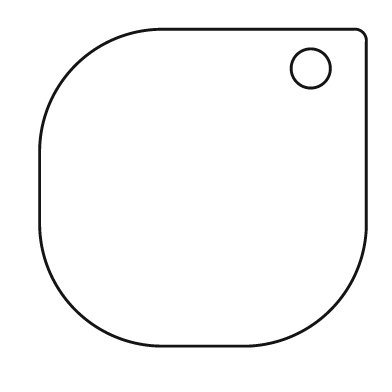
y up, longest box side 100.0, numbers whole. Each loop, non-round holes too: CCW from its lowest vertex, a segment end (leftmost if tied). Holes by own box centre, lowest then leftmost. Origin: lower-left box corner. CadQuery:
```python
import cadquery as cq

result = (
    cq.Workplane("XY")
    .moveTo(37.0, 0.0)
    .lineTo(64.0, 0.0)
    .threePointArc((89.0, 11.0), (100.0, 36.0))
    .lineTo(100.0, 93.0)
    .threePointArc((99.0, 96.0), (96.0, 97.0))
    .lineTo(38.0, 97.0)
    .threePointArc((11.0, 86.0), (0.0, 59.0))
    .lineTo(0.0, 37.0)
    .threePointArc((11.0, 11.0), (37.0, 0.0))
    .close()
    .moveTo(83.0, 85.0)
    .circle(6.0)
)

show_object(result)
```